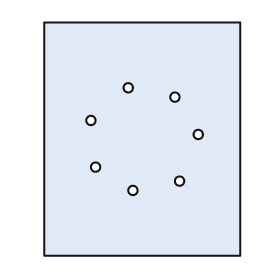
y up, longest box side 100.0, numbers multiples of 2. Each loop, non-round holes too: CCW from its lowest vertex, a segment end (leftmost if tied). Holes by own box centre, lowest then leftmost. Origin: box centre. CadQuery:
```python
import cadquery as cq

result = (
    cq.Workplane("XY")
    .moveTo(-42.0, -50.0)
    .lineTo(42.0, -50.0)
    .lineTo(42.0, 50.0)
    .lineTo(-42.0, 50.0)
    .close()
    .moveTo(-4.0, -22.0)
    .circle(2.0)
    .moveTo(16.0, -18.0)
    .circle(2.0)
    .moveTo(-20.0, -12.0)
    .circle(2.0)
    .moveTo(24.0, 2.0)
    .circle(2.0)
    .moveTo(-22.0, 8.0)
    .circle(2.0)
    .moveTo(14.0, 18.0)
    .circle(2.0)
    .moveTo(-6.0, 22.0)
    .circle(2.0)
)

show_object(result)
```